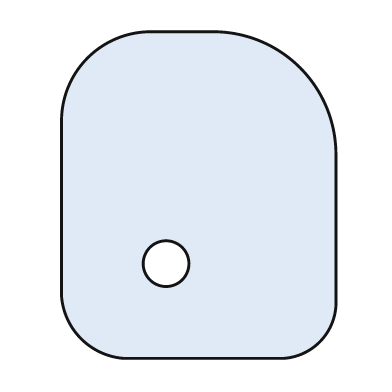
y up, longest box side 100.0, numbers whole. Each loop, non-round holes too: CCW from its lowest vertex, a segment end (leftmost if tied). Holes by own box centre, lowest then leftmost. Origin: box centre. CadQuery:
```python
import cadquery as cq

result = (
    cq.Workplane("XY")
    .moveTo(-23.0, -50.0)
    .lineTo(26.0, -50.0)
    .threePointArc((37.0, -45.0), (42.0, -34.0))
    .lineTo(42.0, 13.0)
    .threePointArc((31.0, 39.0), (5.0, 50.0))
    .lineTo(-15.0, 50.0)
    .threePointArc((-34.0, 42.0), (-42.0, 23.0))
    .lineTo(-42.0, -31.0)
    .threePointArc((-36.0, -44.0), (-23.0, -50.0))
    .close()
    .moveTo(-10.0, -21.0)
    .circle(7.0)
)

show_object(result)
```